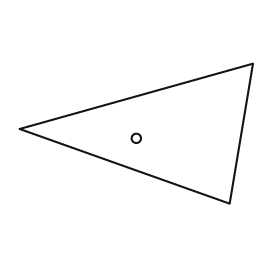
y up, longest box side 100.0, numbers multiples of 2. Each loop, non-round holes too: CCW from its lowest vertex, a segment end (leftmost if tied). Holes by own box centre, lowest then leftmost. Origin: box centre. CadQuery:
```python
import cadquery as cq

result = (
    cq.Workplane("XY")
    .moveTo(40.0, -30.0)
    .lineTo(50.0, 30.0)
    .lineTo(-50.0, 2.0)
    .close()
    .moveTo(0.0, -2.0)
    .circle(2.0)
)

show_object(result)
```